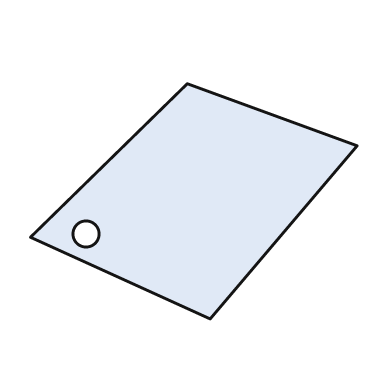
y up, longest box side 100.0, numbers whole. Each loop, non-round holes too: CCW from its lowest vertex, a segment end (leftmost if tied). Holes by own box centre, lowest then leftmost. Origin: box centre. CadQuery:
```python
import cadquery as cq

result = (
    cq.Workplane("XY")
    .moveTo(5.0, -36.0)
    .lineTo(50.0, 17.0)
    .lineTo(-2.0, 36.0)
    .lineTo(-50.0, -11.0)
    .close()
    .moveTo(-33.0, -10.0)
    .circle(4.0)
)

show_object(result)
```